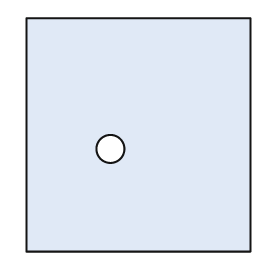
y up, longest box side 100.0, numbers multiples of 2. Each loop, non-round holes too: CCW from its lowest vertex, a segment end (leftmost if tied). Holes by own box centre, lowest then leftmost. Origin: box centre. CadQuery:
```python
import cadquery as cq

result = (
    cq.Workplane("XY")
    .moveTo(-48.0, -50.0)
    .lineTo(48.0, -50.0)
    .lineTo(48.0, 50.0)
    .lineTo(-48.0, 50.0)
    .close()
    .moveTo(-12.0, -6.0)
    .circle(6.0)
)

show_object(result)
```